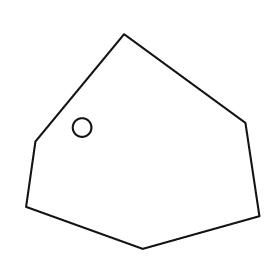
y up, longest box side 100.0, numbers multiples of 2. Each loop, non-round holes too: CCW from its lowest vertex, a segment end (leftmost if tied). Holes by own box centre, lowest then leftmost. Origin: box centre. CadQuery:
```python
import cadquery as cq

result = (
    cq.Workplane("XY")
    .moveTo(0.0, -46.0)
    .lineTo(50.0, -32.0)
    .lineTo(44.0, 8.0)
    .lineTo(-8.0, 46.0)
    .lineTo(-46.0, 0.0)
    .lineTo(-50.0, -28.0)
    .close()
    .moveTo(-26.0, 6.0)
    .circle(4.0)
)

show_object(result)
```